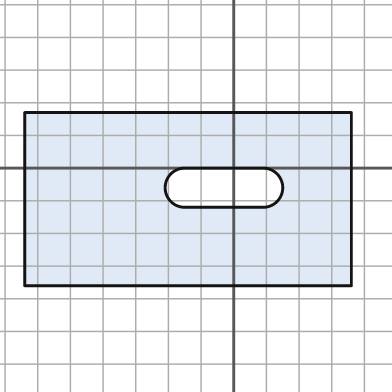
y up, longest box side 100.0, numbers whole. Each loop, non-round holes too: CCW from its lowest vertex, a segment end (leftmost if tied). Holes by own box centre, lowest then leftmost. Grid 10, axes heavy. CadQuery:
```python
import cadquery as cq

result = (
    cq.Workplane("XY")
    .moveTo(-64.0, -36.0)
    .lineTo(36.0, -36.0)
    .lineTo(36.0, 17.0)
    .lineTo(-64.0, 17.0)
    .close()
    .moveTo(-15.0, -12.0)
    .lineTo(9.0, -12.0)
    .threePointArc((15.0, -6.0), (9.0, 0.0))
    .lineTo(-15.0, 0.0)
    .threePointArc((-21.0, -6.0), (-15.0, -12.0))
    .close()
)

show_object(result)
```